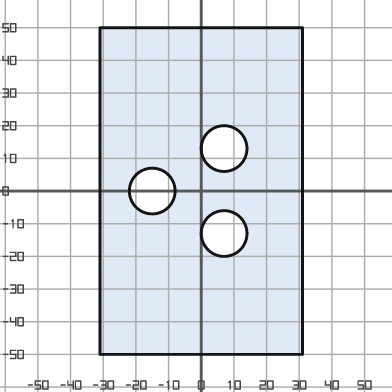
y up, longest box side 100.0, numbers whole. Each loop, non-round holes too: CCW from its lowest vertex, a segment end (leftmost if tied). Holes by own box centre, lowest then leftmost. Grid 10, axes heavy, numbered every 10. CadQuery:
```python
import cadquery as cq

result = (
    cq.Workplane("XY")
    .moveTo(-31.0, -50.0)
    .lineTo(31.0, -50.0)
    .lineTo(31.0, 50.0)
    .lineTo(-31.0, 50.0)
    .close()
    .moveTo(7.0, -13.0)
    .circle(7.0)
    .moveTo(-15.0, 0.0)
    .circle(7.0)
    .moveTo(7.0, 13.0)
    .circle(7.0)
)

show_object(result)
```